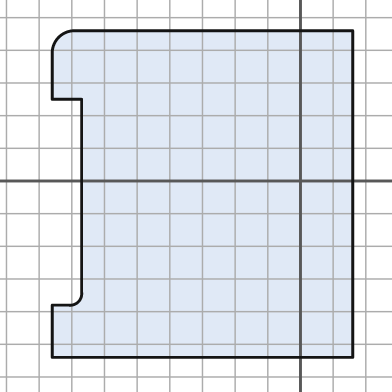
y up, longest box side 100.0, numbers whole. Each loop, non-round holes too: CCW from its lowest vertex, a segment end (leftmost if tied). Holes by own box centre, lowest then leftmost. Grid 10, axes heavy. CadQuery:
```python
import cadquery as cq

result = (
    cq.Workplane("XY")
    .moveTo(-76.0, -54.0)
    .lineTo(16.0, -54.0)
    .lineTo(16.0, 46.0)
    .lineTo(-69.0, 46.0)
    .threePointArc((-74.0, 44.0), (-76.0, 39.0))
    .lineTo(-76.0, 25.0)
    .lineTo(-67.0, 25.0)
    .lineTo(-67.0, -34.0)
    .threePointArc((-68.0, -37.0), (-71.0, -38.0))
    .lineTo(-76.0, -38.0)
    .close()
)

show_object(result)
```